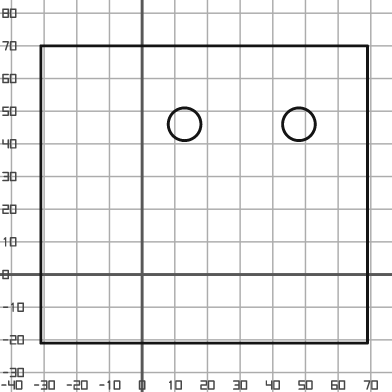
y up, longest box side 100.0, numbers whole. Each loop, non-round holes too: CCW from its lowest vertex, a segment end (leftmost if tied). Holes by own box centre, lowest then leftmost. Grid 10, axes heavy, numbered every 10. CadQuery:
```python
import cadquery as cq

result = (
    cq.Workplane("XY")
    .moveTo(-31.0, -21.0)
    .lineTo(69.0, -21.0)
    .lineTo(69.0, 70.0)
    .lineTo(-31.0, 70.0)
    .close()
    .moveTo(13.0, 46.0)
    .circle(5.0)
    .moveTo(48.0, 46.0)
    .circle(5.0)
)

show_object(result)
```